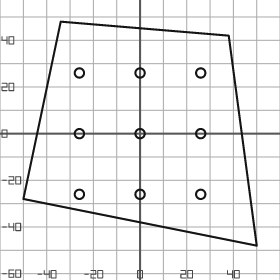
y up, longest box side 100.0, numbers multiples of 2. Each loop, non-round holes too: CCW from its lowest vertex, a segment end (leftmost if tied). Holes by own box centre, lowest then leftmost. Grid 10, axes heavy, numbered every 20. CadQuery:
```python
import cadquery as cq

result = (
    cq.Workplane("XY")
    .moveTo(50.0, -48.0)
    .lineTo(38.0, 42.0)
    .lineTo(-34.0, 48.0)
    .lineTo(-50.0, -28.0)
    .close()
    .moveTo(-26.0, -26.0)
    .circle(2.0)
    .moveTo(0.0, -26.0)
    .circle(2.0)
    .moveTo(26.0, -26.0)
    .circle(2.0)
    .moveTo(-26.0, 0.0)
    .circle(2.0)
    .moveTo(0.0, 0.0)
    .circle(2.0)
    .moveTo(26.0, 0.0)
    .circle(2.0)
    .moveTo(-26.0, 26.0)
    .circle(2.0)
    .moveTo(0.0, 26.0)
    .circle(2.0)
    .moveTo(26.0, 26.0)
    .circle(2.0)
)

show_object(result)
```